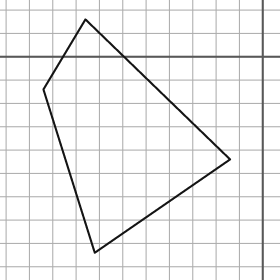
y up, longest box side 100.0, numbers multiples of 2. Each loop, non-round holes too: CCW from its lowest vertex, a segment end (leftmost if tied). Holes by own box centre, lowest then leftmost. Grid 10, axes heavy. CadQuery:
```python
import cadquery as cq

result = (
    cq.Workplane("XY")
    .moveTo(-72.0, -84.0)
    .lineTo(-14.0, -44.0)
    .lineTo(-76.0, 16.0)
    .lineTo(-94.0, -14.0)
    .close()
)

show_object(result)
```